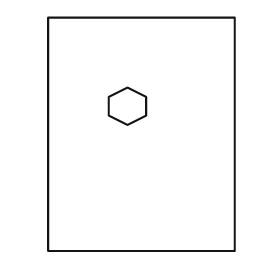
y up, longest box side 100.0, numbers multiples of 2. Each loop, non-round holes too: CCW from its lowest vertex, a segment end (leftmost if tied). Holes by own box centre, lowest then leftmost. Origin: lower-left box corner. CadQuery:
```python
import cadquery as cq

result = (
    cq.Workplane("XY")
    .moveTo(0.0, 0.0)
    .lineTo(80.0, 0.0)
    .lineTo(80.0, 100.0)
    .lineTo(0.0, 100.0)
    .close()
    .moveTo(34.0, 54.0)
    .lineTo(42.0, 58.0)
    .lineTo(42.0, 66.0)
    .lineTo(34.0, 70.0)
    .lineTo(26.0, 66.0)
    .lineTo(26.0, 58.0)
    .close()
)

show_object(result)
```